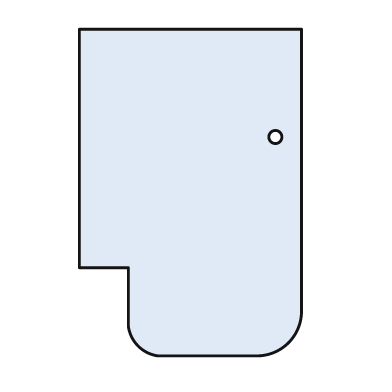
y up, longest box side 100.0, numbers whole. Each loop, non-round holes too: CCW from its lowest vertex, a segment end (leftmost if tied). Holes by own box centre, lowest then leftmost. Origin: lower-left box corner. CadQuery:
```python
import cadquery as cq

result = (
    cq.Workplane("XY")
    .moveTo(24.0, 0.0)
    .lineTo(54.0, 0.0)
    .threePointArc((64.0, 4.0), (68.0, 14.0))
    .lineTo(68.0, 100.0)
    .lineTo(0.0, 100.0)
    .lineTo(0.0, 27.0)
    .lineTo(15.0, 27.0)
    .lineTo(15.0, 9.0)
    .threePointArc((18.0, 3.0), (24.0, 0.0))
    .close()
    .moveTo(60.0, 67.0)
    .circle(2.0)
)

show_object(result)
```